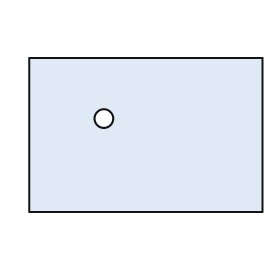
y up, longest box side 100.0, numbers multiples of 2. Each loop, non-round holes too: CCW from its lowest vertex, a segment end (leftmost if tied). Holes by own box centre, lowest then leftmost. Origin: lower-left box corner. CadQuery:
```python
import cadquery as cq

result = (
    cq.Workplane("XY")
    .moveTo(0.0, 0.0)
    .lineTo(100.0, 0.0)
    .lineTo(100.0, 66.0)
    .lineTo(0.0, 66.0)
    .close()
    .moveTo(32.0, 40.0)
    .circle(4.0)
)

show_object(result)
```